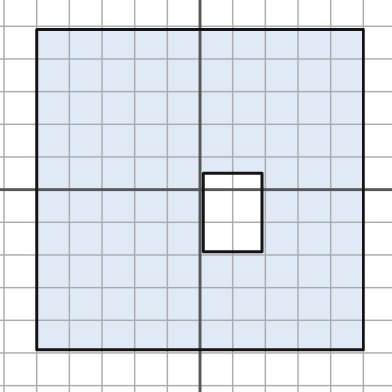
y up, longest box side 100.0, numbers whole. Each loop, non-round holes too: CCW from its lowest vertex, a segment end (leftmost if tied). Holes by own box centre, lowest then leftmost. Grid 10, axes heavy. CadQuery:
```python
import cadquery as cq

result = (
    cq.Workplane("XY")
    .moveTo(-50.0, -49.0)
    .lineTo(50.0, -49.0)
    .lineTo(50.0, 49.0)
    .lineTo(-50.0, 49.0)
    .close()
    .moveTo(1.0, -19.0)
    .lineTo(19.0, -19.0)
    .lineTo(19.0, 5.0)
    .lineTo(1.0, 5.0)
    .close()
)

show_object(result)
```